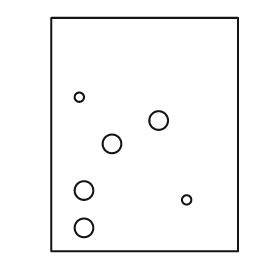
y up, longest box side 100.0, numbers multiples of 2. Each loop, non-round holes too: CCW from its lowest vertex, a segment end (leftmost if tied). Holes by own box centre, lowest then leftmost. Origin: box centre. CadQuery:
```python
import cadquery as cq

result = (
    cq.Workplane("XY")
    .moveTo(-40.0, -50.0)
    .lineTo(40.0, -50.0)
    .lineTo(40.0, 50.0)
    .lineTo(-40.0, 50.0)
    .close()
    .moveTo(-26.0, -40.0)
    .circle(4.0)
    .moveTo(18.0, -28.0)
    .circle(2.0)
    .moveTo(-26.0, -24.0)
    .circle(4.0)
    .moveTo(-14.0, -4.0)
    .circle(4.0)
    .moveTo(6.0, 6.0)
    .circle(4.0)
    .moveTo(-28.0, 16.0)
    .circle(2.0)
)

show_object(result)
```